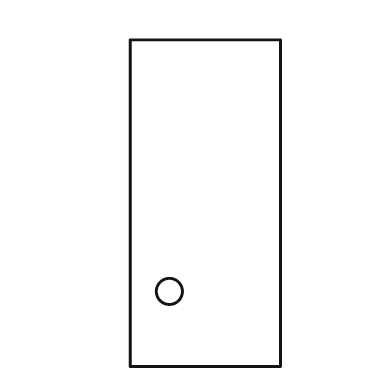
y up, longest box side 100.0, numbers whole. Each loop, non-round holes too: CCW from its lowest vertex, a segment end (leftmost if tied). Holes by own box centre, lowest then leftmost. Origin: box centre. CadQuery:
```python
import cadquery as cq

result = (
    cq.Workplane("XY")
    .moveTo(-23.0, -50.0)
    .lineTo(23.0, -50.0)
    .lineTo(23.0, 50.0)
    .lineTo(-23.0, 50.0)
    .close()
    .moveTo(-11.0, -27.0)
    .circle(4.0)
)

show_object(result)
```